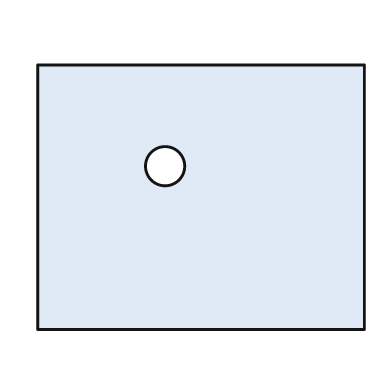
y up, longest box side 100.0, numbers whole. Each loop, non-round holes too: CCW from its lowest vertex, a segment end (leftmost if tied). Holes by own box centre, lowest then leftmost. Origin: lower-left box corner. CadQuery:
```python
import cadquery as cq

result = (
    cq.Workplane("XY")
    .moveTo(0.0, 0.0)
    .lineTo(100.0, 0.0)
    .lineTo(100.0, 81.0)
    .lineTo(0.0, 81.0)
    .close()
    .moveTo(39.0, 50.0)
    .circle(6.0)
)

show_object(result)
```